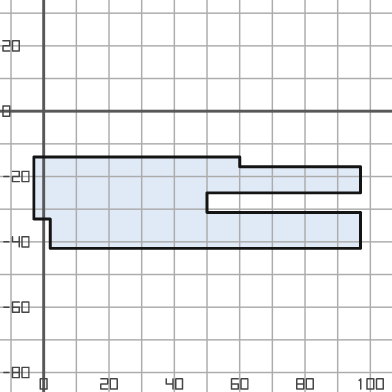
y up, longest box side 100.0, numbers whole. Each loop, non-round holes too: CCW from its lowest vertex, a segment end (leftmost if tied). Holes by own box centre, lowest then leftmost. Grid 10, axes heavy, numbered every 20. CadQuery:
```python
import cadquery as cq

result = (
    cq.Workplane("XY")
    .moveTo(2.0, -42.0)
    .lineTo(97.0, -42.0)
    .lineTo(97.0, -31.0)
    .lineTo(50.0, -31.0)
    .lineTo(50.0, -25.0)
    .lineTo(97.0, -25.0)
    .lineTo(97.0, -17.0)
    .lineTo(60.0, -17.0)
    .lineTo(60.0, -14.0)
    .lineTo(-3.0, -14.0)
    .lineTo(-3.0, -33.0)
    .lineTo(2.0, -33.0)
    .close()
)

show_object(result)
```